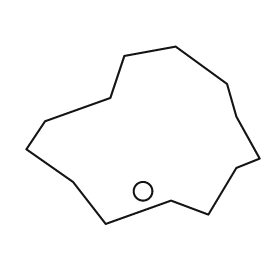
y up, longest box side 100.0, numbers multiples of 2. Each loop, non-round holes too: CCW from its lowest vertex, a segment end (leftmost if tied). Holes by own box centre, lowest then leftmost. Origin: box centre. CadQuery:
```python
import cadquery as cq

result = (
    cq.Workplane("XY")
    .moveTo(-16.0, -38.0)
    .lineTo(12.0, -28.0)
    .lineTo(28.0, -34.0)
    .lineTo(40.0, -14.0)
    .lineTo(50.0, -10.0)
    .lineTo(40.0, 8.0)
    .lineTo(36.0, 22.0)
    .lineTo(14.0, 38.0)
    .lineTo(-8.0, 34.0)
    .lineTo(-14.0, 16.0)
    .lineTo(-42.0, 6.0)
    .lineTo(-50.0, -6.0)
    .lineTo(-30.0, -20.0)
    .close()
    .moveTo(0.0, -24.0)
    .circle(4.0)
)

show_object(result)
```